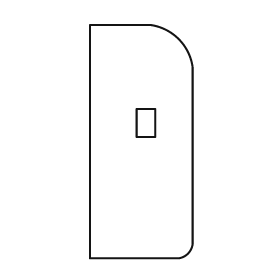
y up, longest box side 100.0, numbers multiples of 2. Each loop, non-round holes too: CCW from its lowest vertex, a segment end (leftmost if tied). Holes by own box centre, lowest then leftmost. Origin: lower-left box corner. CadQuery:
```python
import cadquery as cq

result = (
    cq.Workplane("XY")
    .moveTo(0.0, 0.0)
    .lineTo(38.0, 0.0)
    .threePointArc((42.0, 2.0), (44.0, 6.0))
    .lineTo(44.0, 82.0)
    .threePointArc((38.0, 94.0), (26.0, 100.0))
    .lineTo(0.0, 100.0)
    .close()
    .moveTo(20.0, 52.0)
    .lineTo(28.0, 52.0)
    .lineTo(28.0, 64.0)
    .lineTo(20.0, 64.0)
    .close()
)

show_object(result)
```